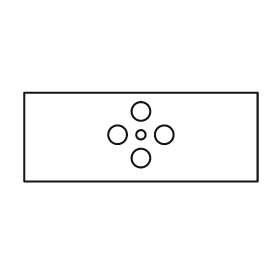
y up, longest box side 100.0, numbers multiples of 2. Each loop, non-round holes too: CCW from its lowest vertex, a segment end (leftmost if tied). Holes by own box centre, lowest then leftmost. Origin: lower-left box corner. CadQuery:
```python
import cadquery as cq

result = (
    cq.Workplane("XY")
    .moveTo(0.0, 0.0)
    .lineTo(100.0, 0.0)
    .lineTo(100.0, 38.0)
    .lineTo(0.0, 38.0)
    .close()
    .moveTo(50.0, 10.0)
    .circle(4.0)
    .moveTo(40.0, 20.0)
    .circle(4.0)
    .moveTo(50.0, 20.0)
    .circle(2.0)
    .moveTo(60.0, 20.0)
    .circle(4.0)
    .moveTo(50.0, 30.0)
    .circle(4.0)
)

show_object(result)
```